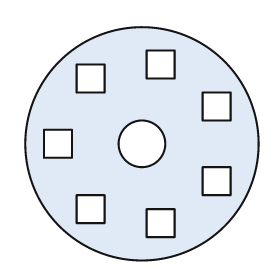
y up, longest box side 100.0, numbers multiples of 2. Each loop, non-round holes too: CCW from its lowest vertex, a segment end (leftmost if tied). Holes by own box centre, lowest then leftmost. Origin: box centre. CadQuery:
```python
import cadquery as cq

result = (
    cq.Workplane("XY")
    .moveTo(0.0, 0.0)
    .circle(50.0)
    .moveTo(2.0, -40.0)
    .lineTo(14.0, -40.0)
    .lineTo(14.0, -28.0)
    .lineTo(2.0, -28.0)
    .close()
    .moveTo(-28.0, -34.0)
    .lineTo(-16.0, -34.0)
    .lineTo(-16.0, -22.0)
    .lineTo(-28.0, -22.0)
    .close()
    .moveTo(26.0, -22.0)
    .lineTo(38.0, -22.0)
    .lineTo(38.0, -10.0)
    .lineTo(26.0, -10.0)
    .close()
    .moveTo(-42.0, -6.0)
    .lineTo(-30.0, -6.0)
    .lineTo(-30.0, 6.0)
    .lineTo(-42.0, 6.0)
    .close()
    .moveTo(0.0, 0.0)
    .circle(10.0)
    .moveTo(26.0, 10.0)
    .lineTo(38.0, 10.0)
    .lineTo(38.0, 22.0)
    .lineTo(26.0, 22.0)
    .close()
    .moveTo(-28.0, 22.0)
    .lineTo(-16.0, 22.0)
    .lineTo(-16.0, 34.0)
    .lineTo(-28.0, 34.0)
    .close()
    .moveTo(2.0, 28.0)
    .lineTo(14.0, 28.0)
    .lineTo(14.0, 40.0)
    .lineTo(2.0, 40.0)
    .close()
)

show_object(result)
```